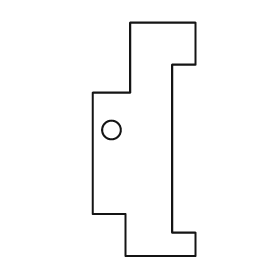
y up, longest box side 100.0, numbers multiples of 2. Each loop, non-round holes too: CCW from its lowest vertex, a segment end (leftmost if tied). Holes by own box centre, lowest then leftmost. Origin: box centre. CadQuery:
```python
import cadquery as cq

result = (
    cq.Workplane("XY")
    .moveTo(-8.0, -50.0)
    .lineTo(22.0, -50.0)
    .lineTo(22.0, -40.0)
    .lineTo(12.0, -40.0)
    .lineTo(12.0, 32.0)
    .lineTo(22.0, 32.0)
    .lineTo(22.0, 50.0)
    .lineTo(-6.0, 50.0)
    .lineTo(-6.0, 20.0)
    .lineTo(-22.0, 20.0)
    .lineTo(-22.0, -32.0)
    .lineTo(-8.0, -32.0)
    .close()
    .moveTo(-14.0, 4.0)
    .circle(4.0)
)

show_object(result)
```